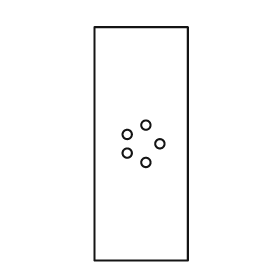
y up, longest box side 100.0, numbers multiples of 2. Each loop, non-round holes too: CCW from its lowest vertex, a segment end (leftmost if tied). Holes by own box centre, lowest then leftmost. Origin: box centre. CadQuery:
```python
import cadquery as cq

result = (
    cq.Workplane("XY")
    .moveTo(-20.0, -50.0)
    .lineTo(20.0, -50.0)
    .lineTo(20.0, 50.0)
    .lineTo(-20.0, 50.0)
    .close()
    .moveTo(2.0, -8.0)
    .circle(2.0)
    .moveTo(-6.0, -4.0)
    .circle(2.0)
    .moveTo(8.0, 0.0)
    .circle(2.0)
    .moveTo(-6.0, 4.0)
    .circle(2.0)
    .moveTo(2.0, 8.0)
    .circle(2.0)
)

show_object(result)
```